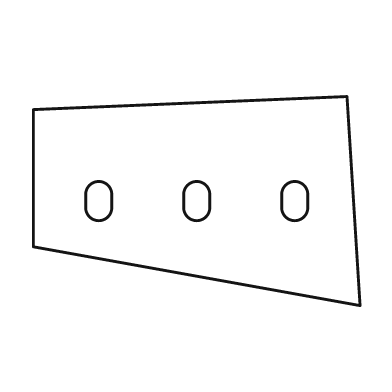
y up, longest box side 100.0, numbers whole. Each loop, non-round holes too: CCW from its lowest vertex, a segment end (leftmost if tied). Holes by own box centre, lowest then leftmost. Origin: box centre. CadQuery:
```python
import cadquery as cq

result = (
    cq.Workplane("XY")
    .moveTo(50.0, -32.0)
    .lineTo(46.0, 32.0)
    .lineTo(-50.0, 28.0)
    .lineTo(-50.0, -14.0)
    .close()
    .moveTo(-34.0, -2.0)
    .threePointArc((-30.0, -6.0), (-26.0, -2.0))
    .lineTo(-26.0, 2.0)
    .threePointArc((-30.0, 6.0), (-34.0, 2.0))
    .close()
    .moveTo(-4.0, -2.0)
    .threePointArc((0.0, -6.0), (4.0, -2.0))
    .lineTo(4.0, 2.0)
    .threePointArc((0.0, 6.0), (-4.0, 2.0))
    .close()
    .moveTo(26.0, -2.0)
    .threePointArc((30.0, -6.0), (34.0, -2.0))
    .lineTo(34.0, 2.0)
    .threePointArc((30.0, 6.0), (26.0, 2.0))
    .close()
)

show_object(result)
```